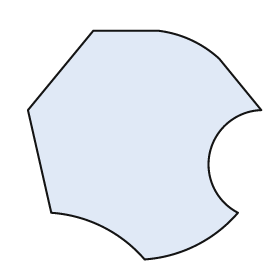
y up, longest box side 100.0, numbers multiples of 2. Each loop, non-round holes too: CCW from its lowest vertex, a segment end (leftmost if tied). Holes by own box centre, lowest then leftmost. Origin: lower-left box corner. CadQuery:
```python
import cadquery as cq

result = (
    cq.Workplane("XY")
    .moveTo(50.0, 0.0)
    .threePointArc((72.0, 6.0), (90.0, 20.0))
    .threePointArc((78.0, 46.0), (100.0, 64.0))
    .lineTo(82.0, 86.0)
    .threePointArc((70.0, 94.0), (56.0, 98.0))
    .lineTo(28.0, 98.0)
    .lineTo(0.0, 64.0)
    .lineTo(10.0, 20.0)
    .threePointArc((32.0, 14.0), (50.0, 0.0))
    .close()
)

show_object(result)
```